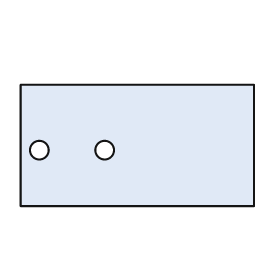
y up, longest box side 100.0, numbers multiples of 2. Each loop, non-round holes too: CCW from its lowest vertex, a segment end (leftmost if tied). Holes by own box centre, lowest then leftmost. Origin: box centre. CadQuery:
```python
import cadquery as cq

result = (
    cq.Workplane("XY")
    .moveTo(-50.0, -26.0)
    .lineTo(50.0, -26.0)
    .lineTo(50.0, 26.0)
    .lineTo(-50.0, 26.0)
    .close()
    .moveTo(-42.0, -2.0)
    .circle(4.0)
    .moveTo(-14.0, -2.0)
    .circle(4.0)
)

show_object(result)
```